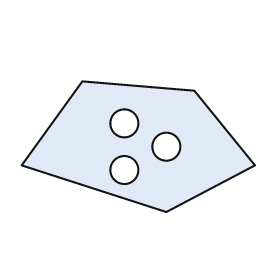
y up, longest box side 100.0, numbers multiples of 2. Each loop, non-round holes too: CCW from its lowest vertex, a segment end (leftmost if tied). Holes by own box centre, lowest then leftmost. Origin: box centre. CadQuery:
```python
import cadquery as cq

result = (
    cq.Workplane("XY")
    .moveTo(12.0, -28.0)
    .lineTo(50.0, -8.0)
    .lineTo(24.0, 24.0)
    .lineTo(-24.0, 28.0)
    .lineTo(-50.0, -8.0)
    .close()
    .moveTo(-6.0, -10.0)
    .circle(6.0)
    .moveTo(12.0, 0.0)
    .circle(6.0)
    .moveTo(-6.0, 10.0)
    .circle(6.0)
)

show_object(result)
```